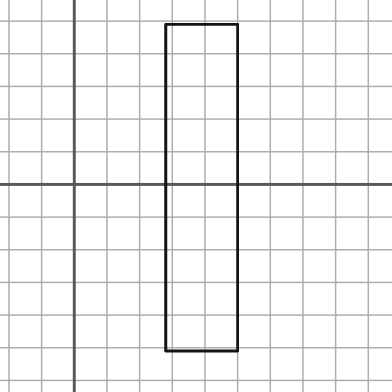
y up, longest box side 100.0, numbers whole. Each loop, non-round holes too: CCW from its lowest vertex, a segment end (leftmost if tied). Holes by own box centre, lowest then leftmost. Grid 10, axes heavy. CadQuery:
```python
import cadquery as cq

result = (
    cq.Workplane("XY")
    .moveTo(28.0, -51.0)
    .lineTo(50.0, -51.0)
    .lineTo(50.0, 49.0)
    .lineTo(28.0, 49.0)
    .close()
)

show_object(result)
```